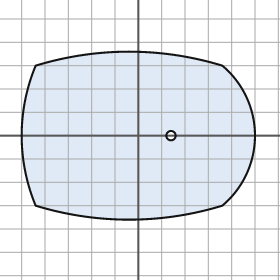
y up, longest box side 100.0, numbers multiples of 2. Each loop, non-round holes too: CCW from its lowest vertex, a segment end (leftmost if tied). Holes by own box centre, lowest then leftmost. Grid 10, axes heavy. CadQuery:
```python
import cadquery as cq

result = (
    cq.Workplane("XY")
    .moveTo(-44.0, -30.0)
    .threePointArc((-4.0, -36.0), (36.0, -30.0))
    .threePointArc((50.0, 0.0), (36.0, 30.0))
    .threePointArc((-4.0, 36.0), (-44.0, 30.0))
    .threePointArc((-50.0, 0.0), (-44.0, -30.0))
    .close()
    .moveTo(14.0, 0.0)
    .circle(2.0)
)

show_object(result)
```